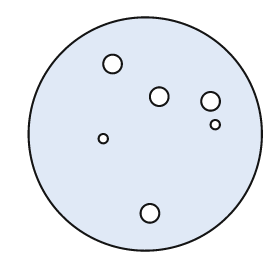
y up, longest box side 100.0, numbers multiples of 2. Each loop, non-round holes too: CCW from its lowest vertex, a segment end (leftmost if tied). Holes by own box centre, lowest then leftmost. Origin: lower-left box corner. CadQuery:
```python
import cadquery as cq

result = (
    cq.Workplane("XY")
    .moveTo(50.0, 50.0)
    .circle(50.0)
    .moveTo(52.0, 16.0)
    .circle(4.0)
    .moveTo(32.0, 48.0)
    .circle(2.0)
    .moveTo(80.0, 54.0)
    .circle(2.0)
    .moveTo(78.0, 64.0)
    .circle(4.0)
    .moveTo(56.0, 66.0)
    .circle(4.0)
    .moveTo(36.0, 80.0)
    .circle(4.0)
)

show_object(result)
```